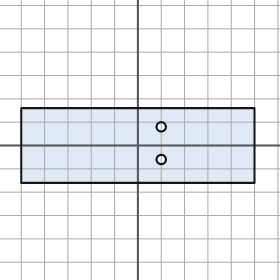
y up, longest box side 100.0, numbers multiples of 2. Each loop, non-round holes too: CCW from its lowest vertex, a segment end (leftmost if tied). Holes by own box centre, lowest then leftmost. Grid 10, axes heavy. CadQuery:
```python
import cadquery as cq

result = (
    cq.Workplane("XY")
    .moveTo(-50.0, -16.0)
    .lineTo(50.0, -16.0)
    .lineTo(50.0, 16.0)
    .lineTo(-50.0, 16.0)
    .close()
    .moveTo(10.0, -6.0)
    .circle(2.0)
    .moveTo(10.0, 8.0)
    .circle(2.0)
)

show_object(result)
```